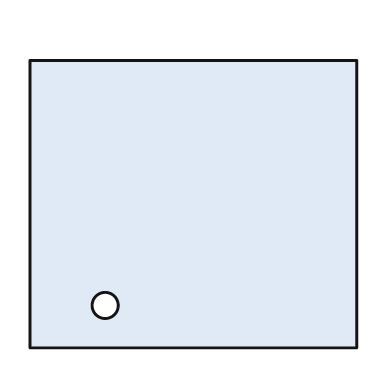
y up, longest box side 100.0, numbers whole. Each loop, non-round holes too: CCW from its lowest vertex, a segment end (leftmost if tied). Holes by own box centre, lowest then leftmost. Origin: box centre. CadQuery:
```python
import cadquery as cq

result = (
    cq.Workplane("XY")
    .moveTo(-50.0, -44.0)
    .lineTo(50.0, -44.0)
    .lineTo(50.0, 44.0)
    .lineTo(-50.0, 44.0)
    .close()
    .moveTo(-27.0, -31.0)
    .circle(4.0)
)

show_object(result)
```